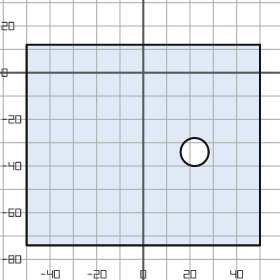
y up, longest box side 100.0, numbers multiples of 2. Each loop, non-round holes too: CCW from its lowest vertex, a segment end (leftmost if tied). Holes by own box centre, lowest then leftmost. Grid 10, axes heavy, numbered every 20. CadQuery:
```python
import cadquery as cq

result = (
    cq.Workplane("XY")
    .moveTo(-50.0, -74.0)
    .lineTo(50.0, -74.0)
    .lineTo(50.0, 12.0)
    .lineTo(-50.0, 12.0)
    .close()
    .moveTo(22.0, -34.0)
    .circle(6.0)
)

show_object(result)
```